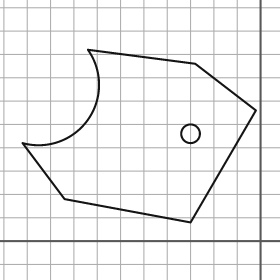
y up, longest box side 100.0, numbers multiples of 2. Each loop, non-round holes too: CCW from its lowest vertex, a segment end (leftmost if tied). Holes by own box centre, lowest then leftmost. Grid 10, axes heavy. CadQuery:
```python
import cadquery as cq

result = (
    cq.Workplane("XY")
    .moveTo(-30.0, 8.0)
    .lineTo(-2.0, 56.0)
    .lineTo(-28.0, 76.0)
    .lineTo(-74.0, 82.0)
    .threePointArc((-74.0, 52.0), (-102.0, 42.0))
    .lineTo(-84.0, 18.0)
    .close()
    .moveTo(-30.0, 46.0)
    .circle(4.0)
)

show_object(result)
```